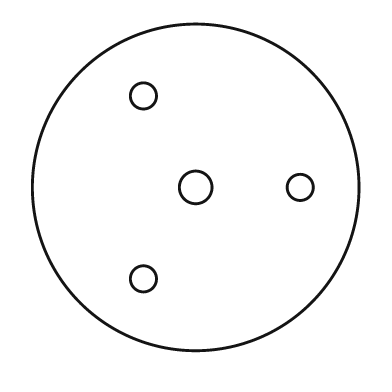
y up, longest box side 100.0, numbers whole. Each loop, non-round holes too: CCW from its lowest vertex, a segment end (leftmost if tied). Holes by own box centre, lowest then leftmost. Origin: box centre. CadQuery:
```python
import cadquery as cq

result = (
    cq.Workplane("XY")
    .moveTo(0.0, 0.0)
    .circle(50.0)
    .moveTo(-16.0, -28.0)
    .circle(4.0)
    .moveTo(0.0, 0.0)
    .circle(5.0)
    .moveTo(32.0, 0.0)
    .circle(4.0)
    .moveTo(-16.0, 28.0)
    .circle(4.0)
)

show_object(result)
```